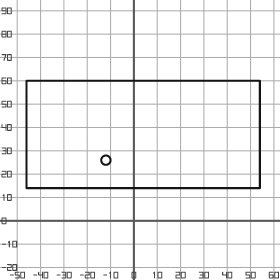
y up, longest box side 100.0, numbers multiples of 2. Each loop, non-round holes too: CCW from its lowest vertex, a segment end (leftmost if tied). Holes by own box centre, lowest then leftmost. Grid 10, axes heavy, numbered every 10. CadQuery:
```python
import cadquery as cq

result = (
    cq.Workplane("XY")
    .moveTo(-46.0, 14.0)
    .lineTo(54.0, 14.0)
    .lineTo(54.0, 60.0)
    .lineTo(-46.0, 60.0)
    .close()
    .moveTo(-12.0, 26.0)
    .circle(2.0)
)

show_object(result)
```